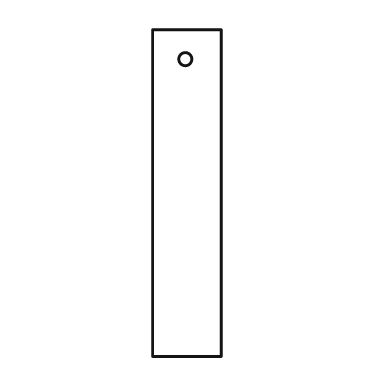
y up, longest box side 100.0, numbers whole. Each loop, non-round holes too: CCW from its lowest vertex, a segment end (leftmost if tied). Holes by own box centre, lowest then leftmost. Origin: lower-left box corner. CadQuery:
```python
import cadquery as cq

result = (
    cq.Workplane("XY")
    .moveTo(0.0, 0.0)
    .lineTo(21.0, 0.0)
    .lineTo(21.0, 100.0)
    .lineTo(0.0, 100.0)
    .close()
    .moveTo(10.0, 91.0)
    .circle(2.0)
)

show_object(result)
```